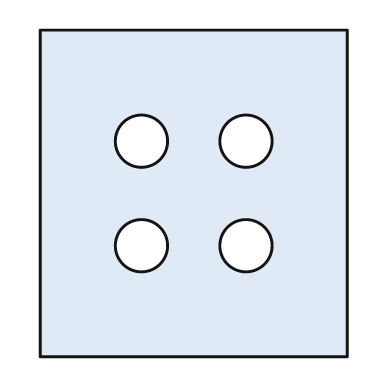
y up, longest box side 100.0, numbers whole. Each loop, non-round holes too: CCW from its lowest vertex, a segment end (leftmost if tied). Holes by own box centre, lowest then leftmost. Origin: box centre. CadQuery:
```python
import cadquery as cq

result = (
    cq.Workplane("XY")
    .moveTo(-47.0, -50.0)
    .lineTo(47.0, -50.0)
    .lineTo(47.0, 50.0)
    .lineTo(-47.0, 50.0)
    .close()
    .moveTo(-16.0, -16.0)
    .circle(8.0)
    .moveTo(16.0, -16.0)
    .circle(8.0)
    .moveTo(-16.0, 16.0)
    .circle(8.0)
    .moveTo(16.0, 16.0)
    .circle(8.0)
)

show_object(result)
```